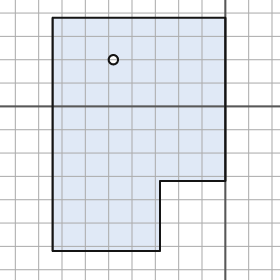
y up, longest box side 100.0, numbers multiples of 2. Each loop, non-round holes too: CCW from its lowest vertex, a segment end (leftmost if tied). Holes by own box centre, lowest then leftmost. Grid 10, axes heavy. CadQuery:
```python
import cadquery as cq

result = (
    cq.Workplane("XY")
    .moveTo(-74.0, -62.0)
    .lineTo(-28.0, -62.0)
    .lineTo(-28.0, -32.0)
    .lineTo(0.0, -32.0)
    .lineTo(0.0, 38.0)
    .lineTo(-74.0, 38.0)
    .close()
    .moveTo(-48.0, 20.0)
    .circle(2.0)
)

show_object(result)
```